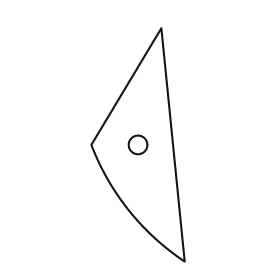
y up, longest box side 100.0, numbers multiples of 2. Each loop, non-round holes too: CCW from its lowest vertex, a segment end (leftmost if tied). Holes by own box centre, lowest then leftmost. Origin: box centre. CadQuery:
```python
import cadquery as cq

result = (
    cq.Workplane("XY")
    .moveTo(20.0, -50.0)
    .lineTo(10.0, 50.0)
    .lineTo(-20.0, 0.0)
    .threePointArc((-4.0, -28.0), (20.0, -50.0))
    .close()
    .moveTo(0.0, 0.0)
    .circle(4.0)
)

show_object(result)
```